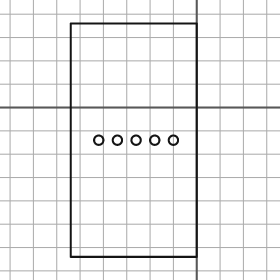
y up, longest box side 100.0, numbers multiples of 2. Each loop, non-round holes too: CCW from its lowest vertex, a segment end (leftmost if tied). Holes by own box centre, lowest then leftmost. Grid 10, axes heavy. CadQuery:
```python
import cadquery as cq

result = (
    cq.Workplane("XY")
    .moveTo(-54.0, -64.0)
    .lineTo(0.0, -64.0)
    .lineTo(0.0, 36.0)
    .lineTo(-54.0, 36.0)
    .close()
    .moveTo(-42.0, -14.0)
    .circle(2.0)
    .moveTo(-34.0, -14.0)
    .circle(2.0)
    .moveTo(-26.0, -14.0)
    .circle(2.0)
    .moveTo(-18.0, -14.0)
    .circle(2.0)
    .moveTo(-10.0, -14.0)
    .circle(2.0)
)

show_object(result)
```